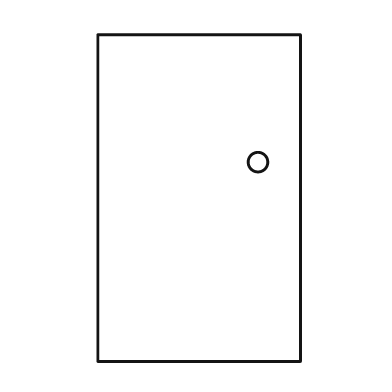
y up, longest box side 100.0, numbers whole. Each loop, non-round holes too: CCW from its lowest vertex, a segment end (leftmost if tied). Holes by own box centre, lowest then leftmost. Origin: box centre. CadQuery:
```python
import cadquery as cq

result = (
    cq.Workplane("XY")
    .moveTo(-31.0, -50.0)
    .lineTo(31.0, -50.0)
    .lineTo(31.0, 50.0)
    .lineTo(-31.0, 50.0)
    .close()
    .moveTo(18.0, 11.0)
    .circle(3.0)
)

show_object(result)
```